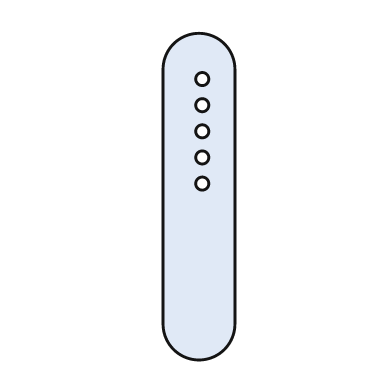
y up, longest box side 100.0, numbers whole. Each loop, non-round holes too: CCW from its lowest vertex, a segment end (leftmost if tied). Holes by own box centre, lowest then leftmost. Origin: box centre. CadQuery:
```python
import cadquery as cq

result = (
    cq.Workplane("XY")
    .moveTo(-11.0, -39.0)
    .threePointArc((0.0, -50.0), (11.0, -39.0))
    .lineTo(11.0, 39.0)
    .threePointArc((0.0, 50.0), (-11.0, 39.0))
    .close()
    .moveTo(1.0, 4.0)
    .circle(2.0)
    .moveTo(1.0, 12.0)
    .circle(2.0)
    .moveTo(1.0, 20.0)
    .circle(2.0)
    .moveTo(1.0, 28.0)
    .circle(2.0)
    .moveTo(1.0, 36.0)
    .circle(2.0)
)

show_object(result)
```